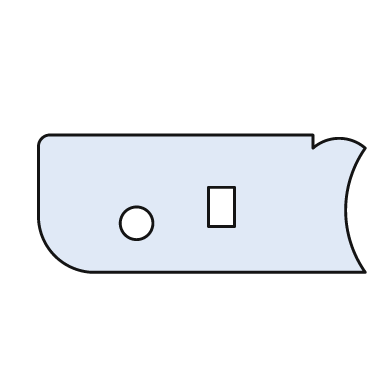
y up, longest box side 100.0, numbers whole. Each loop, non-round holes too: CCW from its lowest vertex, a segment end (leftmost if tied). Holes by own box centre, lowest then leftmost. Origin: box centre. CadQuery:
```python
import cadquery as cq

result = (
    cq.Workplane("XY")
    .moveTo(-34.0, -21.0)
    .lineTo(50.0, -21.0)
    .threePointArc((44.0, -2.0), (50.0, 17.0))
    .threePointArc((42.0, 20.0), (34.0, 17.0))
    .lineTo(34.0, 21.0)
    .lineTo(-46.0, 21.0)
    .threePointArc((-49.0, 20.0), (-50.0, 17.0))
    .lineTo(-50.0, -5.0)
    .threePointArc((-45.0, -16.0), (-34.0, -21.0))
    .close()
    .moveTo(-20.0, -6.0)
    .circle(5.0)
    .moveTo(2.0, -7.0)
    .lineTo(10.0, -7.0)
    .lineTo(10.0, 5.0)
    .lineTo(2.0, 5.0)
    .close()
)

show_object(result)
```